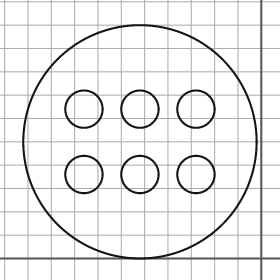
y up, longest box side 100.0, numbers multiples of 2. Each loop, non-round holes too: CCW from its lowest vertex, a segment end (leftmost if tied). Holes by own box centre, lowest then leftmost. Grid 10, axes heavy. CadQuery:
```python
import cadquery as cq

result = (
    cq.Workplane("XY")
    .moveTo(-52.0, 50.0)
    .circle(50.0)
    .moveTo(-76.0, 36.0)
    .circle(8.0)
    .moveTo(-52.0, 36.0)
    .circle(8.0)
    .moveTo(-28.0, 36.0)
    .circle(8.0)
    .moveTo(-76.0, 64.0)
    .circle(8.0)
    .moveTo(-52.0, 64.0)
    .circle(8.0)
    .moveTo(-28.0, 64.0)
    .circle(8.0)
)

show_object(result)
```